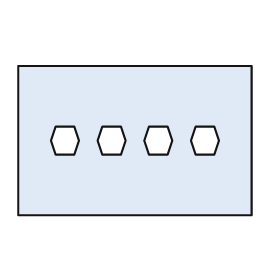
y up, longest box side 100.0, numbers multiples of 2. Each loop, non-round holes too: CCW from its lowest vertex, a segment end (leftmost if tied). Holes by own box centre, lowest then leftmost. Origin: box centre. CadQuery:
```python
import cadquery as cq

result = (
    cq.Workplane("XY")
    .moveTo(-50.0, -32.0)
    .lineTo(50.0, -32.0)
    .lineTo(50.0, 32.0)
    .lineTo(-50.0, 32.0)
    .close()
    .moveTo(-34.0, -6.0)
    .lineTo(-26.0, -6.0)
    .lineTo(-24.0, 0.0)
    .lineTo(-26.0, 6.0)
    .lineTo(-34.0, 6.0)
    .lineTo(-36.0, 0.0)
    .close()
    .moveTo(-14.0, -6.0)
    .lineTo(-6.0, -6.0)
    .lineTo(-4.0, 0.0)
    .lineTo(-6.0, 6.0)
    .lineTo(-14.0, 6.0)
    .lineTo(-16.0, 0.0)
    .close()
    .moveTo(6.0, -6.0)
    .lineTo(14.0, -6.0)
    .lineTo(16.0, 0.0)
    .lineTo(14.0, 6.0)
    .lineTo(6.0, 6.0)
    .lineTo(4.0, 0.0)
    .close()
    .moveTo(26.0, -6.0)
    .lineTo(34.0, -6.0)
    .lineTo(36.0, 0.0)
    .lineTo(34.0, 6.0)
    .lineTo(26.0, 6.0)
    .lineTo(24.0, 0.0)
    .close()
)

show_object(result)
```